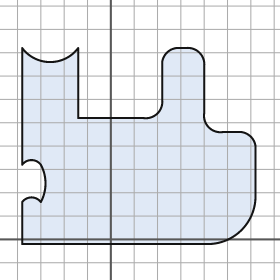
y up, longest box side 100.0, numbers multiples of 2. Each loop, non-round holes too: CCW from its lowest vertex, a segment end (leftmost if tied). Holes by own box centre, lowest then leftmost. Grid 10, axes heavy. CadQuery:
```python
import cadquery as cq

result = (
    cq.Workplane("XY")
    .moveTo(-38.0, -2.0)
    .lineTo(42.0, -2.0)
    .threePointArc((56.0, 4.0), (62.0, 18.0))
    .lineTo(62.0, 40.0)
    .threePointArc((60.0, 44.0), (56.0, 46.0))
    .lineTo(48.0, 46.0)
    .threePointArc((42.0, 48.0), (40.0, 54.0))
    .lineTo(40.0, 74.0)
    .threePointArc((38.0, 80.0), (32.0, 82.0))
    .lineTo(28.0, 82.0)
    .threePointArc((24.0, 80.0), (22.0, 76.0))
    .lineTo(22.0, 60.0)
    .threePointArc((20.0, 54.0), (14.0, 52.0))
    .lineTo(-14.0, 52.0)
    .lineTo(-14.0, 82.0)
    .threePointArc((-26.0, 76.0), (-38.0, 82.0))
    .lineTo(-38.0, 32.0)
    .threePointArc((-34.0, 34.0), (-30.0, 32.0))
    .threePointArc((-28.0, 24.0), (-30.0, 16.0))
    .threePointArc((-34.0, 18.0), (-38.0, 16.0))
    .close()
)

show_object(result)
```